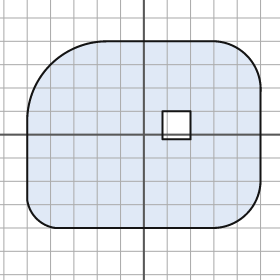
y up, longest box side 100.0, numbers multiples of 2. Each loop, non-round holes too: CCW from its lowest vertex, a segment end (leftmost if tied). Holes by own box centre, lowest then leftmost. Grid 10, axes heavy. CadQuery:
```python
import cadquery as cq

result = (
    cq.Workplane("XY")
    .moveTo(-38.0, -40.0)
    .lineTo(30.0, -40.0)
    .threePointArc((44.0, -34.0), (50.0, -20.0))
    .lineTo(50.0, 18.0)
    .threePointArc((44.0, 34.0), (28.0, 40.0))
    .lineTo(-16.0, 40.0)
    .threePointArc((-40.0, 30.0), (-50.0, 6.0))
    .lineTo(-50.0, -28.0)
    .threePointArc((-46.0, -36.0), (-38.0, -40.0))
    .close()
    .moveTo(8.0, -2.0)
    .lineTo(20.0, -2.0)
    .lineTo(20.0, 10.0)
    .lineTo(8.0, 10.0)
    .close()
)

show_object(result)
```